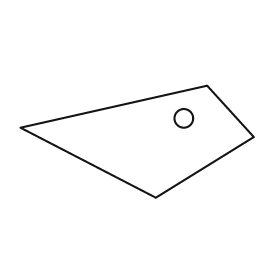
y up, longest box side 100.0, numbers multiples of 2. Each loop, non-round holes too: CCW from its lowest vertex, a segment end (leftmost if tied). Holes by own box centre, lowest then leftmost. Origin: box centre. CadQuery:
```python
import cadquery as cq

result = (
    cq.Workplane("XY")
    .moveTo(8.0, -24.0)
    .lineTo(50.0, 2.0)
    .lineTo(30.0, 24.0)
    .lineTo(-50.0, 6.0)
    .close()
    .moveTo(20.0, 10.0)
    .circle(4.0)
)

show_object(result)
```